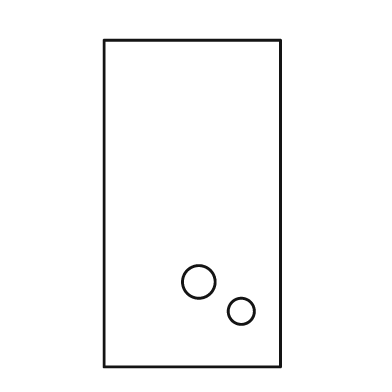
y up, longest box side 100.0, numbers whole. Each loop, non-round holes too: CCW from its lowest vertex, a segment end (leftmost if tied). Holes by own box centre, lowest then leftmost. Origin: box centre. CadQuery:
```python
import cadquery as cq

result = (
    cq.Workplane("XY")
    .moveTo(-27.0, -50.0)
    .lineTo(27.0, -50.0)
    .lineTo(27.0, 50.0)
    .lineTo(-27.0, 50.0)
    .close()
    .moveTo(15.0, -33.0)
    .circle(4.0)
    .moveTo(2.0, -24.0)
    .circle(5.0)
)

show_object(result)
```